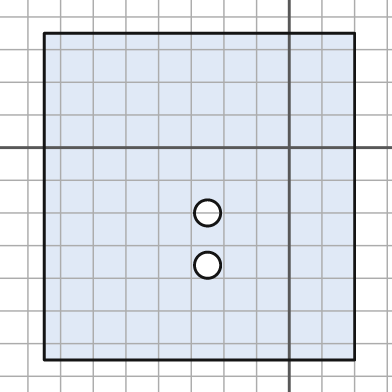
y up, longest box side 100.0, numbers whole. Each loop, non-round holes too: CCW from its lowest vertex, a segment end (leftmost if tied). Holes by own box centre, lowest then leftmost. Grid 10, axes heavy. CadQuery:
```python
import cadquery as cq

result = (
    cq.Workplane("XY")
    .moveTo(-75.0, -65.0)
    .lineTo(20.0, -65.0)
    .lineTo(20.0, 35.0)
    .lineTo(-75.0, 35.0)
    .close()
    .moveTo(-25.0, -36.0)
    .circle(4.0)
    .moveTo(-25.0, -20.0)
    .circle(4.0)
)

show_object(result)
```